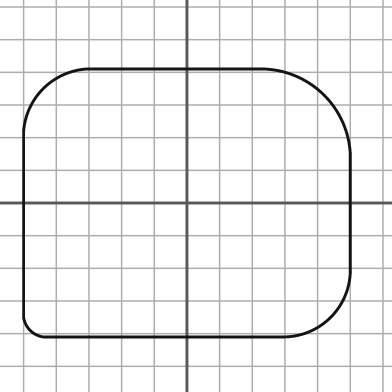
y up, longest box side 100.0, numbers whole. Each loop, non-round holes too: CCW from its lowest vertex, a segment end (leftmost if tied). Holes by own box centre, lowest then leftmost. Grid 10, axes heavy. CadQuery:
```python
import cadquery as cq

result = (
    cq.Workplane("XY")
    .moveTo(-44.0, -41.0)
    .lineTo(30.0, -41.0)
    .threePointArc((44.0, -35.0), (50.0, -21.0))
    .lineTo(50.0, 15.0)
    .threePointArc((42.0, 33.0), (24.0, 41.0))
    .lineTo(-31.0, 41.0)
    .threePointArc((-44.0, 35.0), (-50.0, 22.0))
    .lineTo(-50.0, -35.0)
    .threePointArc((-48.0, -39.0), (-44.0, -41.0))
    .close()
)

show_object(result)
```